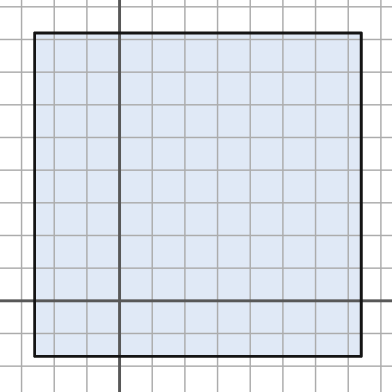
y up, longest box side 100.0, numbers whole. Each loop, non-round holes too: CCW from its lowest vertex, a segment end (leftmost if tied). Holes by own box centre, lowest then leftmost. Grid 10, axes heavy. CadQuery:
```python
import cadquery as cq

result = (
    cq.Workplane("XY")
    .moveTo(-26.0, -17.0)
    .lineTo(74.0, -17.0)
    .lineTo(74.0, 82.0)
    .lineTo(-26.0, 82.0)
    .close()
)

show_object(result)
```